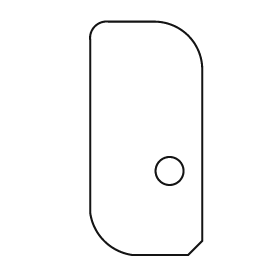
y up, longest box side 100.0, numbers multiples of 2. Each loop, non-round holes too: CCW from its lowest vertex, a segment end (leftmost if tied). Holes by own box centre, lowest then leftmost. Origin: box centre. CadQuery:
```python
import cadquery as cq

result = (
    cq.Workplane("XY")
    .moveTo(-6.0, -50.0)
    .lineTo(18.0, -50.0)
    .lineTo(24.0, -44.0)
    .lineTo(24.0, 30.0)
    .threePointArc((18.0, 44.0), (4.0, 50.0))
    .lineTo(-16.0, 50.0)
    .threePointArc((-22.0, 48.0), (-24.0, 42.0))
    .lineTo(-24.0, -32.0)
    .threePointArc((-18.0, -44.0), (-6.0, -50.0))
    .close()
    .moveTo(10.0, -14.0)
    .circle(6.0)
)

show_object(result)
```